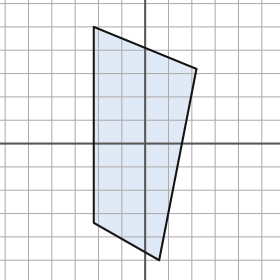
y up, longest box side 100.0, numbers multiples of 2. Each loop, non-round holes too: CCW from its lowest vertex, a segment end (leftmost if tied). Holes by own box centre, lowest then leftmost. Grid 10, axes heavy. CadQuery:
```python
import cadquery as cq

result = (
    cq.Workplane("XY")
    .moveTo(6.0, -50.0)
    .lineTo(22.0, 32.0)
    .lineTo(-22.0, 50.0)
    .lineTo(-22.0, -34.0)
    .close()
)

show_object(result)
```